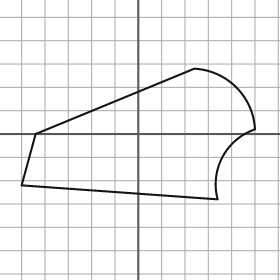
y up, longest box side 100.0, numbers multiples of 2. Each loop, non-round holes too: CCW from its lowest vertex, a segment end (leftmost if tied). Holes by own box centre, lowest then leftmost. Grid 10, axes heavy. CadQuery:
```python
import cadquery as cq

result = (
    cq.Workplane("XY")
    .moveTo(34.0, -28.0)
    .threePointArc((36.0, -10.0), (50.0, 2.0))
    .threePointArc((42.0, 20.0), (24.0, 28.0))
    .lineTo(-44.0, 0.0)
    .lineTo(-50.0, -22.0)
    .close()
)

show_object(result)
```